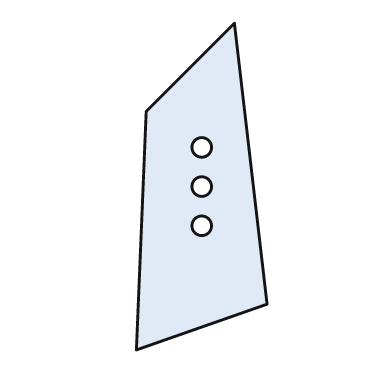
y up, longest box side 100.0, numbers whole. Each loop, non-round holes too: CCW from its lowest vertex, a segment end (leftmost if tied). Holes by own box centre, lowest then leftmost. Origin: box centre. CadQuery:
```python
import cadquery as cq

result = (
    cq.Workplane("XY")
    .moveTo(-20.0, -50.0)
    .lineTo(20.0, -36.0)
    .lineTo(10.0, 50.0)
    .lineTo(-17.0, 23.0)
    .close()
    .moveTo(0.0, -12.0)
    .circle(3.0)
    .moveTo(0.0, 0.0)
    .circle(3.0)
    .moveTo(0.0, 12.0)
    .circle(3.0)
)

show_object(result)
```